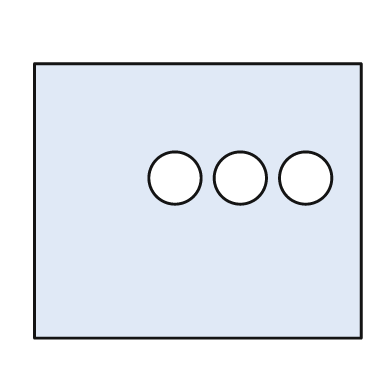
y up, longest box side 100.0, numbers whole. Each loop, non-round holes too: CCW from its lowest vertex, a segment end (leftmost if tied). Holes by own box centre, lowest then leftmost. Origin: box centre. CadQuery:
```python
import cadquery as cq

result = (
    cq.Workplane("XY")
    .moveTo(-50.0, -42.0)
    .lineTo(50.0, -42.0)
    .lineTo(50.0, 42.0)
    .lineTo(-50.0, 42.0)
    .close()
    .moveTo(-7.0, 7.0)
    .circle(8.0)
    .moveTo(13.0, 7.0)
    .circle(8.0)
    .moveTo(33.0, 7.0)
    .circle(8.0)
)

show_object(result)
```